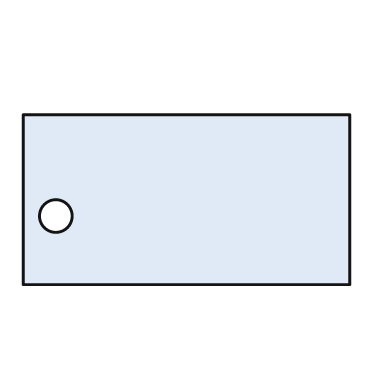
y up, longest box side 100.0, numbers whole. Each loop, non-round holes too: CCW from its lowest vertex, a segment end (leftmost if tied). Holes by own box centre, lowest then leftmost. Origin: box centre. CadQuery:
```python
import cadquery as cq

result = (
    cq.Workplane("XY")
    .moveTo(-50.0, -26.0)
    .lineTo(50.0, -26.0)
    .lineTo(50.0, 26.0)
    .lineTo(-50.0, 26.0)
    .close()
    .moveTo(-40.0, -5.0)
    .circle(5.0)
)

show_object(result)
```